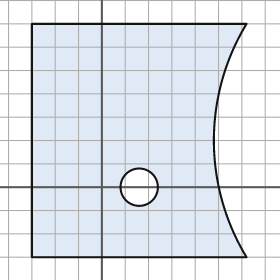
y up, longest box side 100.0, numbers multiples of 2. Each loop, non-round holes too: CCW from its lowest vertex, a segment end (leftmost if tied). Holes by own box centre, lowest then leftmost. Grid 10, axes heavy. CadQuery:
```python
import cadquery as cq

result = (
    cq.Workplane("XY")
    .moveTo(-30.0, -30.0)
    .lineTo(62.0, -30.0)
    .threePointArc((48.0, 20.0), (62.0, 70.0))
    .lineTo(-30.0, 70.0)
    .close()
    .moveTo(16.0, 0.0)
    .circle(8.0)
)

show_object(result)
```